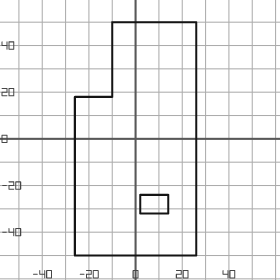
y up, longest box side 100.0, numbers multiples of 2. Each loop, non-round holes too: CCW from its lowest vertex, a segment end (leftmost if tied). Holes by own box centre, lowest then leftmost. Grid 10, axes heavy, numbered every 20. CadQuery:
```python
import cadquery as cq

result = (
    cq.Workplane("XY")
    .moveTo(-26.0, -50.0)
    .lineTo(26.0, -50.0)
    .lineTo(26.0, 50.0)
    .lineTo(-10.0, 50.0)
    .lineTo(-10.0, 18.0)
    .lineTo(-26.0, 18.0)
    .close()
    .moveTo(2.0, -32.0)
    .lineTo(14.0, -32.0)
    .lineTo(14.0, -24.0)
    .lineTo(2.0, -24.0)
    .close()
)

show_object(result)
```